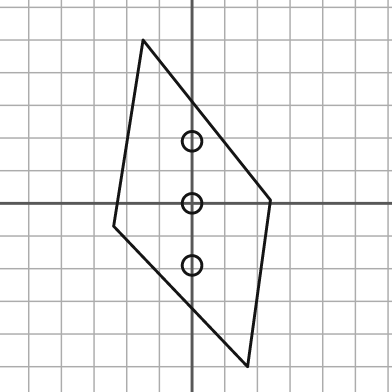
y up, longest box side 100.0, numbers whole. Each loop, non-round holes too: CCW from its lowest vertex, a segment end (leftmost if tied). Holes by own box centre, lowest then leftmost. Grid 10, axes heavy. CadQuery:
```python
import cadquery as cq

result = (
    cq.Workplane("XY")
    .moveTo(17.0, -50.0)
    .lineTo(24.0, 1.0)
    .lineTo(-15.0, 50.0)
    .lineTo(-24.0, -7.0)
    .close()
    .moveTo(0.0, -19.0)
    .circle(3.0)
    .moveTo(0.0, 0.0)
    .circle(3.0)
    .moveTo(0.0, 19.0)
    .circle(3.0)
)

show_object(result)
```